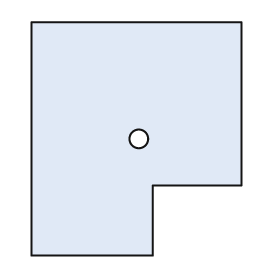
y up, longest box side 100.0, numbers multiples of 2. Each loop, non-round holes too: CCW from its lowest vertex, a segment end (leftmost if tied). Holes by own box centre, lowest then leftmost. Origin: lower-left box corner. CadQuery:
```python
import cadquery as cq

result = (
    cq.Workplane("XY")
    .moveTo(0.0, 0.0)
    .lineTo(52.0, 0.0)
    .lineTo(52.0, 30.0)
    .lineTo(90.0, 30.0)
    .lineTo(90.0, 100.0)
    .lineTo(0.0, 100.0)
    .close()
    .moveTo(46.0, 50.0)
    .circle(4.0)
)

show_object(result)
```